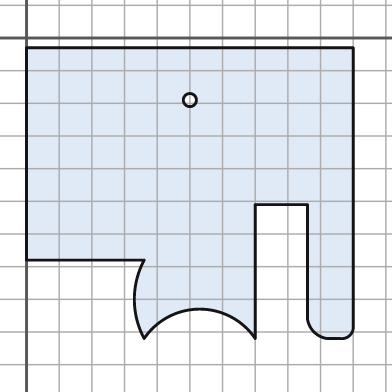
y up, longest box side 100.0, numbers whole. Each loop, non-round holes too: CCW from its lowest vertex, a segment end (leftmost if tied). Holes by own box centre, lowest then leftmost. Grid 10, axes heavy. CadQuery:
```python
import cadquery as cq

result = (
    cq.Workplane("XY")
    .moveTo(36.0, -92.0)
    .threePointArc((53.0, -83.0), (70.0, -92.0))
    .lineTo(70.0, -51.0)
    .lineTo(86.0, -51.0)
    .lineTo(86.0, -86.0)
    .threePointArc((88.0, -90.0), (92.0, -92.0))
    .lineTo(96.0, -92.0)
    .threePointArc((99.0, -91.0), (100.0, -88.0))
    .lineTo(100.0, -3.0)
    .lineTo(0.0, -3.0)
    .lineTo(0.0, -68.0)
    .lineTo(36.0, -68.0)
    .threePointArc((33.0, -80.0), (36.0, -92.0))
    .close()
    .moveTo(50.0, -19.0)
    .circle(2.0)
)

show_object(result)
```